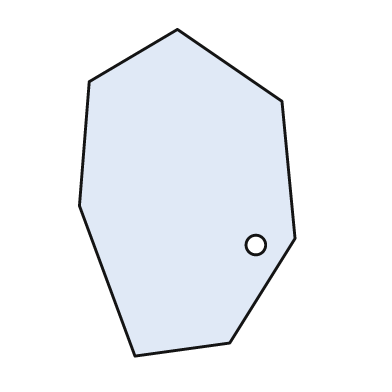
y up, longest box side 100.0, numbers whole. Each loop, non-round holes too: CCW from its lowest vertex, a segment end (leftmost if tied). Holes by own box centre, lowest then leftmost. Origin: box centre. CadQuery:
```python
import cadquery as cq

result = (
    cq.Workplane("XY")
    .moveTo(-16.0, -50.0)
    .lineTo(13.0, -46.0)
    .lineTo(33.0, -14.0)
    .lineTo(29.0, 28.0)
    .lineTo(-3.0, 50.0)
    .lineTo(-30.0, 34.0)
    .lineTo(-33.0, -4.0)
    .close()
    .moveTo(21.0, -16.0)
    .circle(3.0)
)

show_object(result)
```